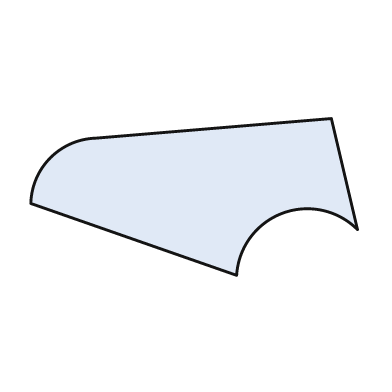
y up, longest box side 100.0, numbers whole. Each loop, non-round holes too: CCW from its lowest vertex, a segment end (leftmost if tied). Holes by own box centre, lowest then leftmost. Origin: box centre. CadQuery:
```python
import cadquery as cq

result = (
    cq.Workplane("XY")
    .moveTo(13.0, -24.0)
    .threePointArc((27.0, -5.0), (50.0, -10.0))
    .lineTo(42.0, 24.0)
    .lineTo(-30.0, 18.0)
    .threePointArc((-44.0, 12.0), (-50.0, -2.0))
    .close()
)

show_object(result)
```